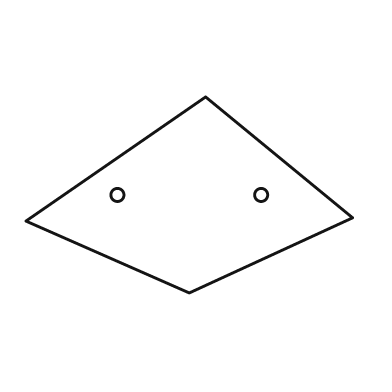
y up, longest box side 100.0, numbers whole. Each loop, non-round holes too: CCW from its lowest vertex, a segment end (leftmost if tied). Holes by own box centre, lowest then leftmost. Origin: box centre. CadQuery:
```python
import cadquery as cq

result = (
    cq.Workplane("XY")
    .moveTo(0.0, -30.0)
    .lineTo(50.0, -7.0)
    .lineTo(5.0, 30.0)
    .lineTo(-50.0, -8.0)
    .close()
    .moveTo(-22.0, 0.0)
    .circle(2.0)
    .moveTo(22.0, 0.0)
    .circle(2.0)
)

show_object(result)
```